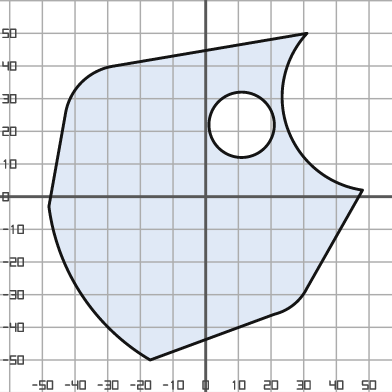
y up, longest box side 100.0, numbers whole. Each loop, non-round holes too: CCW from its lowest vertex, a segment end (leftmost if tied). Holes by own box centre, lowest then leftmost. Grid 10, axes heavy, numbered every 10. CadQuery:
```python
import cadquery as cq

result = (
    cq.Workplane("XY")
    .moveTo(-17.0, -50.0)
    .lineTo(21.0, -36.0)
    .threePointArc((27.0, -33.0), (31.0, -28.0))
    .lineTo(48.0, 2.0)
    .threePointArc((25.0, 21.0), (31.0, 50.0))
    .lineTo(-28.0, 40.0)
    .threePointArc((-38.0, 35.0), (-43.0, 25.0))
    .lineTo(-48.0, -3.0)
    .threePointArc((-38.0, -30.0), (-17.0, -50.0))
    .close()
    .moveTo(11.0, 22.0)
    .circle(10.0)
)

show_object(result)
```